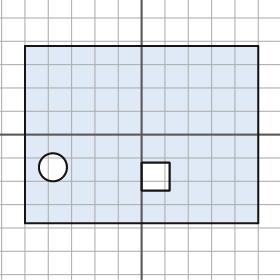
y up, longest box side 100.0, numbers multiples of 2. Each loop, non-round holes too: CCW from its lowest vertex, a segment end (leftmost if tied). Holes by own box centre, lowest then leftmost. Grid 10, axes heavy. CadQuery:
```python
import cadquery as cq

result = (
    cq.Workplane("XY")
    .moveTo(-50.0, -38.0)
    .lineTo(50.0, -38.0)
    .lineTo(50.0, 38.0)
    .lineTo(-50.0, 38.0)
    .close()
    .moveTo(0.0, -24.0)
    .lineTo(12.0, -24.0)
    .lineTo(12.0, -12.0)
    .lineTo(0.0, -12.0)
    .close()
    .moveTo(-38.0, -14.0)
    .circle(6.0)
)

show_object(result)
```